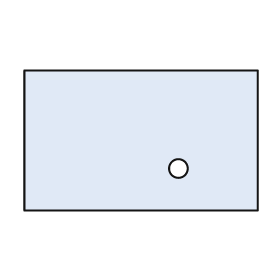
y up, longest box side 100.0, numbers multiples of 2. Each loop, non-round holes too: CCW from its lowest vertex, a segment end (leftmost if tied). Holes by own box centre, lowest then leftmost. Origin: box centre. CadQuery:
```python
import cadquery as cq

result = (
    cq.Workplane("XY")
    .moveTo(-50.0, -30.0)
    .lineTo(50.0, -30.0)
    .lineTo(50.0, 30.0)
    .lineTo(-50.0, 30.0)
    .close()
    .moveTo(16.0, -12.0)
    .circle(4.0)
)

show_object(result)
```